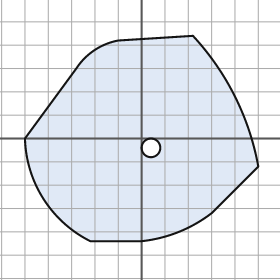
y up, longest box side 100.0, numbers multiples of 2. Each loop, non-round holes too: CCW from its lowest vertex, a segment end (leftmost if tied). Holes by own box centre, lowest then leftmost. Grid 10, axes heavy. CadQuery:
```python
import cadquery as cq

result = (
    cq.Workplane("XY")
    .moveTo(-22.0, -44.0)
    .lineTo(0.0, -44.0)
    .threePointArc((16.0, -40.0), (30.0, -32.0))
    .lineTo(50.0, -12.0)
    .threePointArc((40.0, 18.0), (22.0, 44.0))
    .lineTo(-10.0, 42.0)
    .threePointArc((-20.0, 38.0), (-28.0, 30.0))
    .lineTo(-50.0, 0.0)
    .threePointArc((-42.0, -26.0), (-22.0, -44.0))
    .close()
    .moveTo(4.0, -4.0)
    .circle(4.0)
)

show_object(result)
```